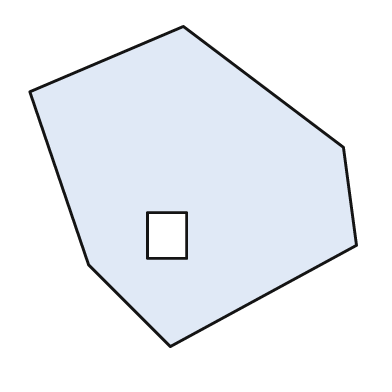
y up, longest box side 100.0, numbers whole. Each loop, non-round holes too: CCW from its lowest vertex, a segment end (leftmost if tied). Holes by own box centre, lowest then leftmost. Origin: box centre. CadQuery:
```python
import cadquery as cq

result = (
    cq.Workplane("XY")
    .moveTo(-7.0, -49.0)
    .lineTo(50.0, -18.0)
    .lineTo(46.0, 12.0)
    .lineTo(-3.0, 49.0)
    .lineTo(-50.0, 29.0)
    .lineTo(-32.0, -24.0)
    .close()
    .moveTo(-14.0, -22.0)
    .lineTo(-2.0, -22.0)
    .lineTo(-2.0, -8.0)
    .lineTo(-14.0, -8.0)
    .close()
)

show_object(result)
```